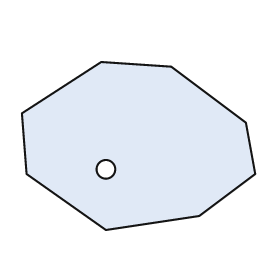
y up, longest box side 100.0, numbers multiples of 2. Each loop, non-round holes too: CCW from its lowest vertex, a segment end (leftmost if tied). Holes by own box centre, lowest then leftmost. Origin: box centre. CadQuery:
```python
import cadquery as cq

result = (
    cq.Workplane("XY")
    .moveTo(-14.0, -36.0)
    .lineTo(26.0, -30.0)
    .lineTo(50.0, -12.0)
    .lineTo(46.0, 10.0)
    .lineTo(14.0, 34.0)
    .lineTo(-16.0, 36.0)
    .lineTo(-50.0, 14.0)
    .lineTo(-48.0, -12.0)
    .close()
    .moveTo(-14.0, -10.0)
    .circle(4.0)
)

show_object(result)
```